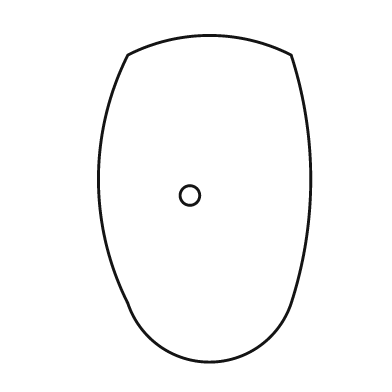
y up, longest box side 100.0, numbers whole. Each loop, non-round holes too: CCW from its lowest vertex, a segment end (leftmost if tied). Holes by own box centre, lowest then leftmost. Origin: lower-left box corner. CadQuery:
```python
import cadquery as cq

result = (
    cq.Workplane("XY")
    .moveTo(9.0, 18.0)
    .threePointArc((34.0, 0.0), (59.0, 18.0))
    .threePointArc((65.0, 56.0), (59.0, 94.0))
    .threePointArc((34.0, 100.0), (9.0, 94.0))
    .threePointArc((0.0, 56.0), (9.0, 18.0))
    .close()
    .moveTo(28.0, 51.0)
    .circle(3.0)
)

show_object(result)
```